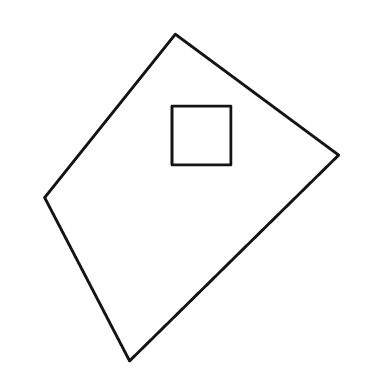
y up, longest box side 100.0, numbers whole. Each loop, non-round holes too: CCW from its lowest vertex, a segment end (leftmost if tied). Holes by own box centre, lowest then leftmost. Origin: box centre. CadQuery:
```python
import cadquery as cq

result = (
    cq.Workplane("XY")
    .moveTo(-19.0, -50.0)
    .lineTo(45.0, 13.0)
    .lineTo(-5.0, 50.0)
    .lineTo(-45.0, 0.0)
    .close()
    .moveTo(-6.0, 10.0)
    .lineTo(12.0, 10.0)
    .lineTo(12.0, 28.0)
    .lineTo(-6.0, 28.0)
    .close()
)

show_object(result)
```